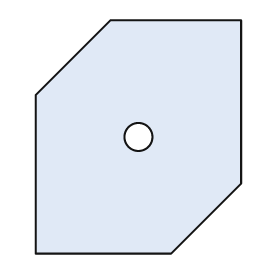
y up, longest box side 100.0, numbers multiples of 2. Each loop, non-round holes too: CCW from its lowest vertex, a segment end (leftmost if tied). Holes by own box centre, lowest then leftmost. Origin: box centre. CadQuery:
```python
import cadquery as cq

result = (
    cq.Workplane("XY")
    .moveTo(-44.0, -50.0)
    .lineTo(14.0, -50.0)
    .lineTo(44.0, -20.0)
    .lineTo(44.0, 50.0)
    .lineTo(-12.0, 50.0)
    .lineTo(-44.0, 18.0)
    .close()
    .moveTo(0.0, 0.0)
    .circle(6.0)
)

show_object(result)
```